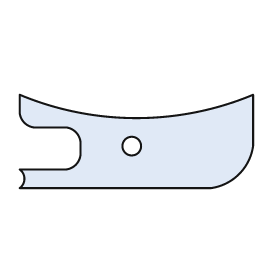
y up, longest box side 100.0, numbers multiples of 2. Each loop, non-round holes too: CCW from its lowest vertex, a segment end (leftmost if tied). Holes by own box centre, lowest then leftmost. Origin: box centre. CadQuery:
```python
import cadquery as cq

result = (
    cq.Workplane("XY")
    .moveTo(-50.0, -20.0)
    .lineTo(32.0, -20.0)
    .threePointArc((44.0, -14.0), (50.0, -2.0))
    .lineTo(50.0, 20.0)
    .threePointArc((0.0, 10.0), (-50.0, 20.0))
    .lineTo(-50.0, 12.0)
    .threePointArc((-48.0, 8.0), (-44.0, 6.0))
    .lineTo(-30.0, 6.0)
    .threePointArc((-26.0, 4.0), (-24.0, 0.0))
    .lineTo(-24.0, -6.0)
    .threePointArc((-26.0, -10.0), (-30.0, -12.0))
    .lineTo(-50.0, -12.0)
    .threePointArc((-48.0, -16.0), (-50.0, -20.0))
    .close()
    .moveTo(-2.0, -2.0)
    .circle(4.0)
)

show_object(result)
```